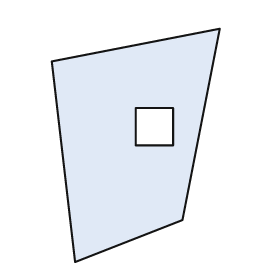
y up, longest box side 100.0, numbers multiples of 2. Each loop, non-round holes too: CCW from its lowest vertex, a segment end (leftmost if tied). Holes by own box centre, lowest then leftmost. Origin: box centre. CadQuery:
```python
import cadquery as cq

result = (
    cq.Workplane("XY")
    .moveTo(-26.0, -50.0)
    .lineTo(20.0, -32.0)
    .lineTo(36.0, 50.0)
    .lineTo(-36.0, 36.0)
    .close()
    .moveTo(0.0, 0.0)
    .lineTo(16.0, 0.0)
    .lineTo(16.0, 16.0)
    .lineTo(0.0, 16.0)
    .close()
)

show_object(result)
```